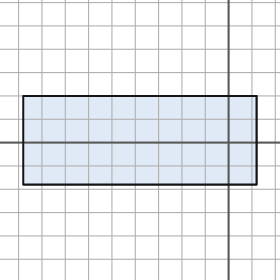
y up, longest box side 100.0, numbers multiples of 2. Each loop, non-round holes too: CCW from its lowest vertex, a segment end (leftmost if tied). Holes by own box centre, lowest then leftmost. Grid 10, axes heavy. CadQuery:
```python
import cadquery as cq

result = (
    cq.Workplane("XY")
    .moveTo(-88.0, -18.0)
    .lineTo(12.0, -18.0)
    .lineTo(12.0, 20.0)
    .lineTo(-88.0, 20.0)
    .close()
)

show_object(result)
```